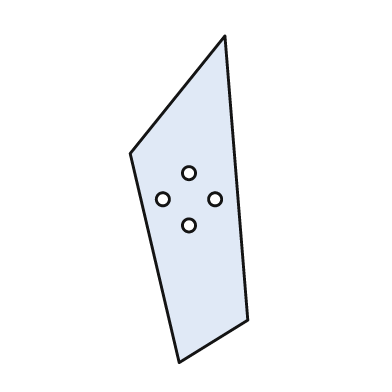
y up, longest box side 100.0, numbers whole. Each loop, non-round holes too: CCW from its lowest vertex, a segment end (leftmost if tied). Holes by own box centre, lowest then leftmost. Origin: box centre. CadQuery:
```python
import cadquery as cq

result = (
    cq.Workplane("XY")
    .moveTo(-3.0, -50.0)
    .lineTo(18.0, -37.0)
    .lineTo(11.0, 50.0)
    .lineTo(-18.0, 14.0)
    .close()
    .moveTo(0.0, -8.0)
    .circle(2.0)
    .moveTo(-8.0, 0.0)
    .circle(2.0)
    .moveTo(8.0, 0.0)
    .circle(2.0)
    .moveTo(0.0, 8.0)
    .circle(2.0)
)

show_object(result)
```